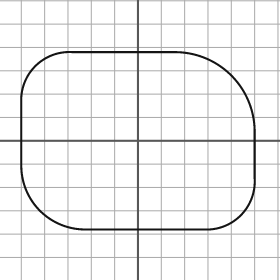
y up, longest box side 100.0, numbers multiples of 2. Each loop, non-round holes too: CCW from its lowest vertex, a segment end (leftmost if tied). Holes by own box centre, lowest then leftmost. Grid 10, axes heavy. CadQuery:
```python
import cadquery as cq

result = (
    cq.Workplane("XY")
    .moveTo(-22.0, -38.0)
    .lineTo(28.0, -38.0)
    .threePointArc((44.0, -32.0), (50.0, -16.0))
    .lineTo(50.0, 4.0)
    .threePointArc((40.0, 28.0), (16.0, 38.0))
    .lineTo(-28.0, 38.0)
    .threePointArc((-44.0, 32.0), (-50.0, 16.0))
    .lineTo(-50.0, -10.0)
    .threePointArc((-42.0, -30.0), (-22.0, -38.0))
    .close()
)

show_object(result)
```